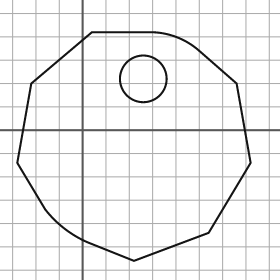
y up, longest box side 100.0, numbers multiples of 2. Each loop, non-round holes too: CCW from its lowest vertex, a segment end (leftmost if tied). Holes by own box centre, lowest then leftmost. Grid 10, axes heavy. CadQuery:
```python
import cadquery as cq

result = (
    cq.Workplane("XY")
    .moveTo(22.0, -56.0)
    .lineTo(54.0, -44.0)
    .lineTo(72.0, -14.0)
    .lineTo(66.0, 20.0)
    .lineTo(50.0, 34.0)
    .threePointArc((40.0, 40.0), (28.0, 42.0))
    .lineTo(4.0, 42.0)
    .lineTo(-22.0, 20.0)
    .lineTo(-28.0, -14.0)
    .lineTo(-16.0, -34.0)
    .threePointArc((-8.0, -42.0), (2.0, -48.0))
    .close()
    .moveTo(26.0, 22.0)
    .circle(10.0)
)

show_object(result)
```